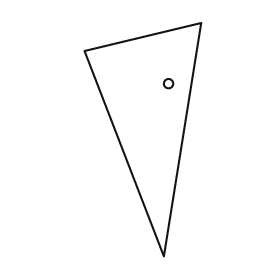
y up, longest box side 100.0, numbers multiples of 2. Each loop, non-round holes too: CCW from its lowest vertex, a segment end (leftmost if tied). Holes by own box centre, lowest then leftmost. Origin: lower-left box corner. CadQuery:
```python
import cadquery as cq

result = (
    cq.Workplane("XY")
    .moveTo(34.0, 0.0)
    .lineTo(50.0, 100.0)
    .lineTo(0.0, 88.0)
    .close()
    .moveTo(36.0, 74.0)
    .circle(2.0)
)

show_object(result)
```